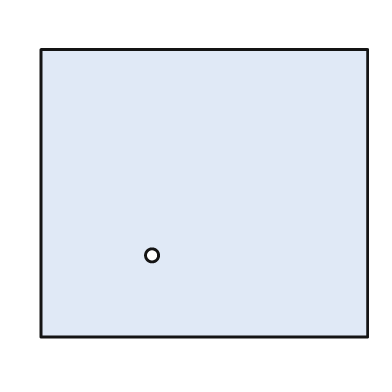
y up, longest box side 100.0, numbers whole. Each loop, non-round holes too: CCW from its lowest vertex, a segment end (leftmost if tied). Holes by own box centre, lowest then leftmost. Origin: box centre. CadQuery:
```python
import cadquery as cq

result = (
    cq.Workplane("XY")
    .moveTo(-50.0, -44.0)
    .lineTo(50.0, -44.0)
    .lineTo(50.0, 44.0)
    .lineTo(-50.0, 44.0)
    .close()
    .moveTo(-16.0, -19.0)
    .circle(2.0)
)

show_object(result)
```